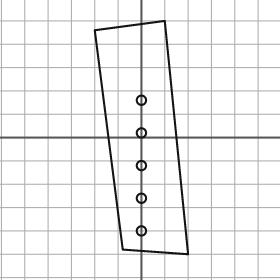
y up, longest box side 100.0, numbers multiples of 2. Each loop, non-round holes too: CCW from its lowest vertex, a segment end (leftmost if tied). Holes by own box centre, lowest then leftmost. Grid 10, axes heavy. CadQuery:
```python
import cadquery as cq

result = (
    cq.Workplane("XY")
    .moveTo(20.0, -50.0)
    .lineTo(10.0, 50.0)
    .lineTo(-20.0, 46.0)
    .lineTo(-8.0, -48.0)
    .close()
    .moveTo(0.0, -40.0)
    .circle(2.0)
    .moveTo(0.0, -26.0)
    .circle(2.0)
    .moveTo(0.0, -12.0)
    .circle(2.0)
    .moveTo(0.0, 2.0)
    .circle(2.0)
    .moveTo(0.0, 16.0)
    .circle(2.0)
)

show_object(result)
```